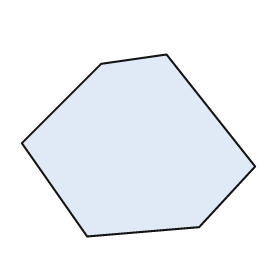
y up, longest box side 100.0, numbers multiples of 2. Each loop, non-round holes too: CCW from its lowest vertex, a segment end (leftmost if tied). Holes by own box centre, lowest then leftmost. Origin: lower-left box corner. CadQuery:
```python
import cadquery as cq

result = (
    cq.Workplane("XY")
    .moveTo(28.0, 0.0)
    .lineTo(76.0, 4.0)
    .lineTo(100.0, 30.0)
    .lineTo(62.0, 78.0)
    .lineTo(34.0, 74.0)
    .lineTo(0.0, 40.0)
    .close()
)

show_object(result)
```